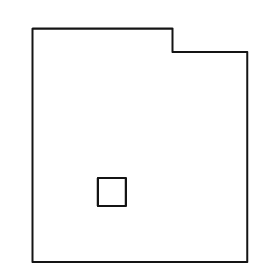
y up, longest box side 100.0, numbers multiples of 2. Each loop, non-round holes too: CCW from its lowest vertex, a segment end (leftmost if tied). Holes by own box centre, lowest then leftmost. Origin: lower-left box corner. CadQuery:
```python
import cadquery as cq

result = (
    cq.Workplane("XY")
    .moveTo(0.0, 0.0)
    .lineTo(92.0, 0.0)
    .lineTo(92.0, 90.0)
    .lineTo(60.0, 90.0)
    .lineTo(60.0, 100.0)
    .lineTo(0.0, 100.0)
    .close()
    .moveTo(28.0, 24.0)
    .lineTo(40.0, 24.0)
    .lineTo(40.0, 36.0)
    .lineTo(28.0, 36.0)
    .close()
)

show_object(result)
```